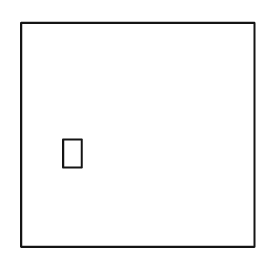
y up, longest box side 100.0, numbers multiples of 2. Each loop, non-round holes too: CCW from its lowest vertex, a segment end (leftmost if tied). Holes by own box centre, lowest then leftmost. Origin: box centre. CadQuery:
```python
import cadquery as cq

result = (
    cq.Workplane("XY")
    .moveTo(-50.0, -48.0)
    .lineTo(50.0, -48.0)
    .lineTo(50.0, 48.0)
    .lineTo(-50.0, 48.0)
    .close()
    .moveTo(-32.0, -14.0)
    .lineTo(-24.0, -14.0)
    .lineTo(-24.0, -2.0)
    .lineTo(-32.0, -2.0)
    .close()
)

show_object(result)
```